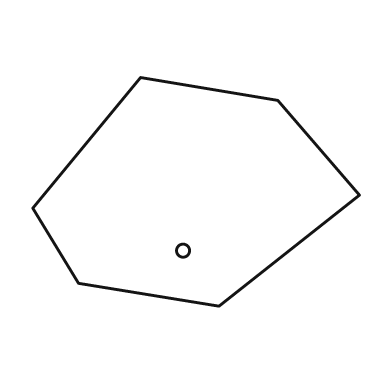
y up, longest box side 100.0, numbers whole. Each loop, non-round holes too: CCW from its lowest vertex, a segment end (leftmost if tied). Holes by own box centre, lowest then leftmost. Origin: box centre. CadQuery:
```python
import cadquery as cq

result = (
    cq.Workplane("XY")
    .moveTo(7.0, -35.0)
    .lineTo(50.0, -1.0)
    .lineTo(25.0, 28.0)
    .lineTo(-17.0, 35.0)
    .lineTo(-50.0, -5.0)
    .lineTo(-36.0, -28.0)
    .close()
    .moveTo(-4.0, -18.0)
    .circle(2.0)
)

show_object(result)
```